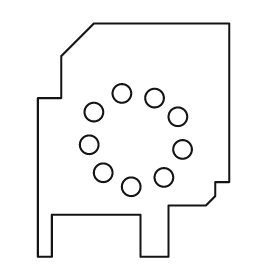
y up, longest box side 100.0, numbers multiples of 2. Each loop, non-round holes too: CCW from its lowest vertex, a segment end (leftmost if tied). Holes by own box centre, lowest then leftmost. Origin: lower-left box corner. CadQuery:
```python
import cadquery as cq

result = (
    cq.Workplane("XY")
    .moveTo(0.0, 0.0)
    .lineTo(6.0, 0.0)
    .lineTo(6.0, 18.0)
    .lineTo(44.0, 18.0)
    .lineTo(44.0, 0.0)
    .lineTo(56.0, 0.0)
    .lineTo(56.0, 22.0)
    .lineTo(72.0, 22.0)
    .lineTo(76.0, 26.0)
    .lineTo(76.0, 32.0)
    .lineTo(82.0, 32.0)
    .lineTo(82.0, 100.0)
    .lineTo(24.0, 100.0)
    .lineTo(10.0, 86.0)
    .lineTo(10.0, 68.0)
    .lineTo(0.0, 68.0)
    .close()
    .moveTo(40.0, 30.0)
    .circle(4.0)
    .moveTo(54.0, 34.0)
    .circle(4.0)
    .moveTo(28.0, 36.0)
    .circle(4.0)
    .moveTo(62.0, 46.0)
    .circle(4.0)
    .moveTo(22.0, 48.0)
    .circle(4.0)
    .moveTo(60.0, 60.0)
    .circle(4.0)
    .moveTo(24.0, 62.0)
    .circle(4.0)
    .moveTo(50.0, 68.0)
    .circle(4.0)
    .moveTo(36.0, 70.0)
    .circle(4.0)
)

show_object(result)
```